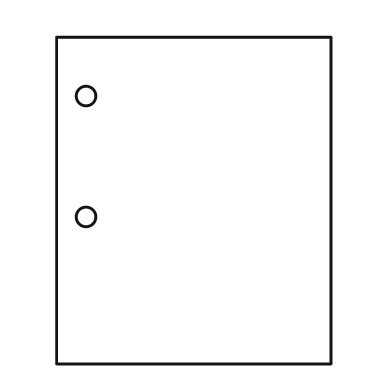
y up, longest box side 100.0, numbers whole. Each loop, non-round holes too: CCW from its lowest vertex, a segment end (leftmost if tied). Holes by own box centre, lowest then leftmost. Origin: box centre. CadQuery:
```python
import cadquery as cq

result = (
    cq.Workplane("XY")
    .moveTo(-42.0, -50.0)
    .lineTo(42.0, -50.0)
    .lineTo(42.0, 50.0)
    .lineTo(-42.0, 50.0)
    .close()
    .moveTo(-33.0, -5.0)
    .circle(3.0)
    .moveTo(-33.0, 32.0)
    .circle(3.0)
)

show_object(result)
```